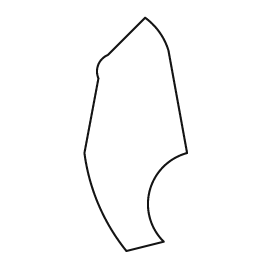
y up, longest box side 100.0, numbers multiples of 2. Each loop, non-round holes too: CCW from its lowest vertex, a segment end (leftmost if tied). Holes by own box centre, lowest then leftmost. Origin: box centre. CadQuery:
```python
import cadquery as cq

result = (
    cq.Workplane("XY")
    .moveTo(-4.0, -50.0)
    .lineTo(12.0, -46.0)
    .threePointArc((6.0, -24.0), (22.0, -8.0))
    .lineTo(14.0, 36.0)
    .threePointArc((10.0, 44.0), (4.0, 50.0))
    .lineTo(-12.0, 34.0)
    .threePointArc((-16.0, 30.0), (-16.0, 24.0))
    .lineTo(-22.0, -8.0)
    .threePointArc((-16.0, -30.0), (-4.0, -50.0))
    .close()
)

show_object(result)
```